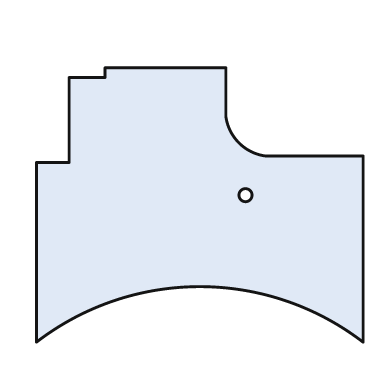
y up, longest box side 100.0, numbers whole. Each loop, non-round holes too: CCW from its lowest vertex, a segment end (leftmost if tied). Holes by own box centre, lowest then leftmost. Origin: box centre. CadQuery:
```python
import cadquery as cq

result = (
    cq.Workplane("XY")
    .moveTo(-50.0, -42.0)
    .threePointArc((0.0, -25.0), (50.0, -42.0))
    .lineTo(50.0, 15.0)
    .lineTo(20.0, 15.0)
    .threePointArc((12.0, 19.0), (8.0, 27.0))
    .lineTo(8.0, 42.0)
    .lineTo(-29.0, 42.0)
    .lineTo(-29.0, 39.0)
    .lineTo(-40.0, 39.0)
    .lineTo(-40.0, 13.0)
    .lineTo(-50.0, 13.0)
    .close()
    .moveTo(14.0, 3.0)
    .circle(2.0)
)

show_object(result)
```